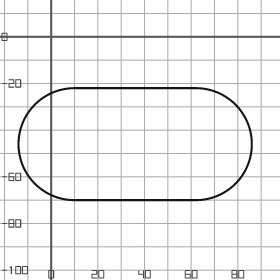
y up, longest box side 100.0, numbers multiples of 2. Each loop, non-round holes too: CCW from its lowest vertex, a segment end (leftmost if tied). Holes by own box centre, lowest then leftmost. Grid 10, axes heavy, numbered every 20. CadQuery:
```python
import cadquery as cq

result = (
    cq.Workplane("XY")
    .moveTo(10.0, -70.0)
    .lineTo(62.0, -70.0)
    .threePointArc((86.0, -46.0), (62.0, -22.0))
    .lineTo(10.0, -22.0)
    .threePointArc((-14.0, -46.0), (10.0, -70.0))
    .close()
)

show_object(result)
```